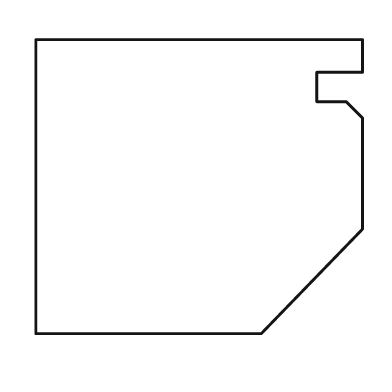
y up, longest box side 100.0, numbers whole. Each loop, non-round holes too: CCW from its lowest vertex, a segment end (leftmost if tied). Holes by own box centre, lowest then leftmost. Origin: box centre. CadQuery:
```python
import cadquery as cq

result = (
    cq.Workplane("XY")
    .moveTo(-50.0, -45.0)
    .lineTo(19.0, -45.0)
    .lineTo(50.0, -13.0)
    .lineTo(50.0, 21.0)
    .lineTo(45.0, 26.0)
    .lineTo(36.0, 26.0)
    .lineTo(36.0, 35.0)
    .lineTo(50.0, 35.0)
    .lineTo(50.0, 45.0)
    .lineTo(-50.0, 45.0)
    .close()
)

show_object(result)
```